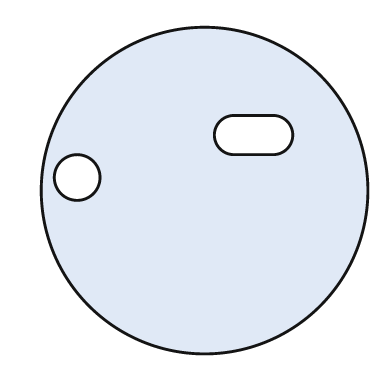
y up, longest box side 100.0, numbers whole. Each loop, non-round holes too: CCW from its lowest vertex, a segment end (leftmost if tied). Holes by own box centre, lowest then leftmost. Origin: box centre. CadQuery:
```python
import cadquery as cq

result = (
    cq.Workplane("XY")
    .moveTo(0.0, 0.0)
    .circle(50.0)
    .moveTo(-39.0, 4.0)
    .circle(7.0)
    .moveTo(9.0, 11.0)
    .lineTo(21.0, 11.0)
    .threePointArc((27.0, 17.0), (21.0, 23.0))
    .lineTo(9.0, 23.0)
    .threePointArc((3.0, 17.0), (9.0, 11.0))
    .close()
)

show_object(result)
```